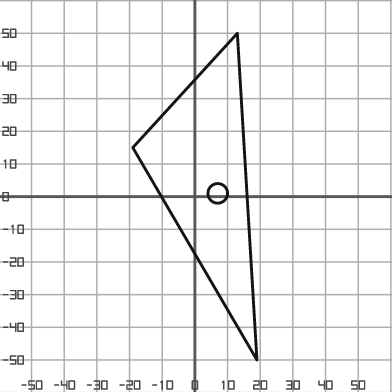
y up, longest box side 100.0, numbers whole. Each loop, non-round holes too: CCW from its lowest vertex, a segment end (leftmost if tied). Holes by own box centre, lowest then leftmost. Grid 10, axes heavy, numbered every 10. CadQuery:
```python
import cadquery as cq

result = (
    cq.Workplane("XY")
    .moveTo(19.0, -50.0)
    .lineTo(13.0, 50.0)
    .lineTo(-19.0, 15.0)
    .close()
    .moveTo(7.0, 1.0)
    .circle(3.0)
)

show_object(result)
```